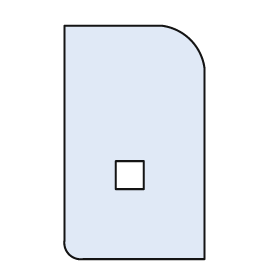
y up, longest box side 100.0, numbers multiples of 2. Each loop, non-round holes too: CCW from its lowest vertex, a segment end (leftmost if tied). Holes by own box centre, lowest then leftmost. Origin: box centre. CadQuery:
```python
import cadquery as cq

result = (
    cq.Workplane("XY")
    .moveTo(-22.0, -50.0)
    .lineTo(30.0, -50.0)
    .lineTo(30.0, 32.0)
    .threePointArc((24.0, 44.0), (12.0, 50.0))
    .lineTo(-30.0, 50.0)
    .lineTo(-30.0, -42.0)
    .threePointArc((-28.0, -48.0), (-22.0, -50.0))
    .close()
    .moveTo(-8.0, -20.0)
    .lineTo(4.0, -20.0)
    .lineTo(4.0, -8.0)
    .lineTo(-8.0, -8.0)
    .close()
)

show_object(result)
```